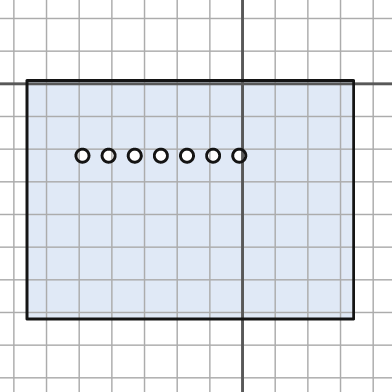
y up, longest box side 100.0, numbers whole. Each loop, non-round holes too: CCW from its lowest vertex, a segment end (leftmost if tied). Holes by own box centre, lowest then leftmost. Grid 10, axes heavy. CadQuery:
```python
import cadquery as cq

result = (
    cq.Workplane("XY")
    .moveTo(-66.0, -72.0)
    .lineTo(34.0, -72.0)
    .lineTo(34.0, 1.0)
    .lineTo(-66.0, 1.0)
    .close()
    .moveTo(-49.0, -22.0)
    .circle(2.0)
    .moveTo(-41.0, -22.0)
    .circle(2.0)
    .moveTo(-33.0, -22.0)
    .circle(2.0)
    .moveTo(-25.0, -22.0)
    .circle(2.0)
    .moveTo(-17.0, -22.0)
    .circle(2.0)
    .moveTo(-9.0, -22.0)
    .circle(2.0)
    .moveTo(-1.0, -22.0)
    .circle(2.0)
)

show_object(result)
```